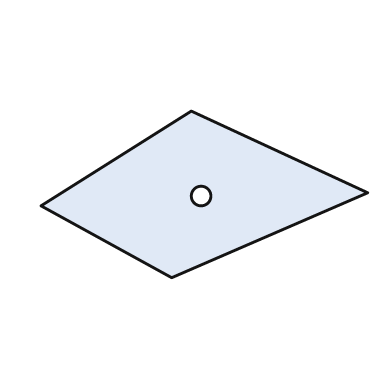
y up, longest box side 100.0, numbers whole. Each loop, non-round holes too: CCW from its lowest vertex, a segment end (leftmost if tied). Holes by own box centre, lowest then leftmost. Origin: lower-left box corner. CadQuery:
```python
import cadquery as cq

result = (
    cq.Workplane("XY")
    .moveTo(40.0, 0.0)
    .lineTo(100.0, 26.0)
    .lineTo(46.0, 51.0)
    .lineTo(0.0, 22.0)
    .close()
    .moveTo(49.0, 25.0)
    .circle(3.0)
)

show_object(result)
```